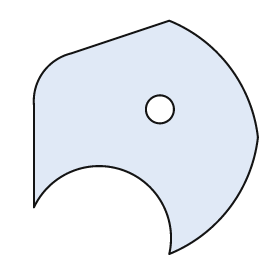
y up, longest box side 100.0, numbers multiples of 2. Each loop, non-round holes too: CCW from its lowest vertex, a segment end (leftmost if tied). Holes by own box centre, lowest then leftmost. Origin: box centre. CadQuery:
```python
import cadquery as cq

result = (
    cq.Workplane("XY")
    .moveTo(10.0, -50.0)
    .threePointArc((36.0, -30.0), (48.0, 0.0))
    .threePointArc((36.0, 30.0), (10.0, 50.0))
    .lineTo(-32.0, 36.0)
    .threePointArc((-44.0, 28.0), (-48.0, 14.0))
    .lineTo(-48.0, -30.0)
    .threePointArc((-10.0, -14.0), (10.0, -50.0))
    .close()
    .moveTo(6.0, 12.0)
    .circle(6.0)
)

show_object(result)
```